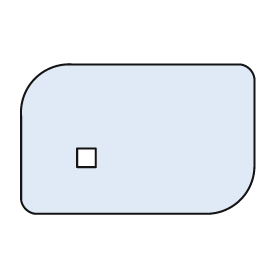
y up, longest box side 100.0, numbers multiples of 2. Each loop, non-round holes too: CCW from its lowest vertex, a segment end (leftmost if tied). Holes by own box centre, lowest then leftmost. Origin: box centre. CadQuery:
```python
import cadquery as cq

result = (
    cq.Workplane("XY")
    .moveTo(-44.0, -32.0)
    .lineTo(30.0, -32.0)
    .threePointArc((44.0, -26.0), (50.0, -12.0))
    .lineTo(50.0, 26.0)
    .threePointArc((48.0, 30.0), (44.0, 32.0))
    .lineTo(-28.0, 32.0)
    .threePointArc((-44.0, 26.0), (-50.0, 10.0))
    .lineTo(-50.0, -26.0)
    .threePointArc((-48.0, -30.0), (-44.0, -32.0))
    .close()
    .moveTo(-26.0, -12.0)
    .lineTo(-18.0, -12.0)
    .lineTo(-18.0, -4.0)
    .lineTo(-26.0, -4.0)
    .close()
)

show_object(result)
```